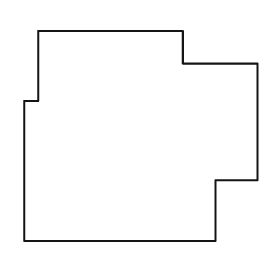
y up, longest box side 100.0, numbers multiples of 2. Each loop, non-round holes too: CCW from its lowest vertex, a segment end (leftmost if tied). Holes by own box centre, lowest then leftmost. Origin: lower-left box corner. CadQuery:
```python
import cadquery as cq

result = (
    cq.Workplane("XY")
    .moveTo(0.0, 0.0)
    .lineTo(82.0, 0.0)
    .lineTo(82.0, 26.0)
    .lineTo(100.0, 26.0)
    .lineTo(100.0, 76.0)
    .lineTo(68.0, 76.0)
    .lineTo(68.0, 90.0)
    .lineTo(6.0, 90.0)
    .lineTo(6.0, 60.0)
    .lineTo(0.0, 60.0)
    .close()
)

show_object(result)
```